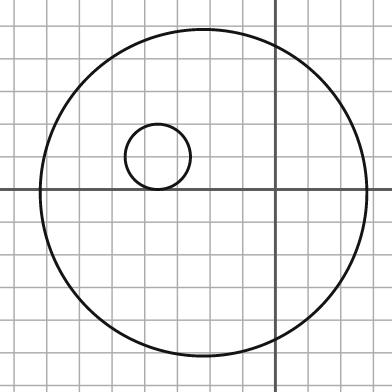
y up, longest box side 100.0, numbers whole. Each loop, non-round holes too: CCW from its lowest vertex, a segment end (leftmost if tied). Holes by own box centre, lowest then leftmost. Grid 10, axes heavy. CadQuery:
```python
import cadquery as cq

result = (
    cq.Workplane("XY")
    .moveTo(-22.0, -1.0)
    .circle(50.0)
    .moveTo(-36.0, 10.0)
    .circle(10.0)
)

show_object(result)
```